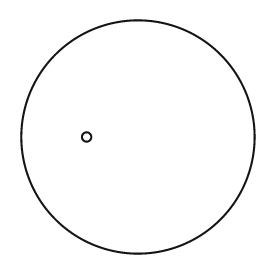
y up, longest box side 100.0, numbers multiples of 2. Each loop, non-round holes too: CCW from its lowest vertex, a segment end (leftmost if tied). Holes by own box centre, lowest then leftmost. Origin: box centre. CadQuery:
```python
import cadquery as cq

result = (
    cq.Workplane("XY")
    .moveTo(0.0, 0.0)
    .circle(50.0)
    .moveTo(-22.0, 0.0)
    .circle(2.0)
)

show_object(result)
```